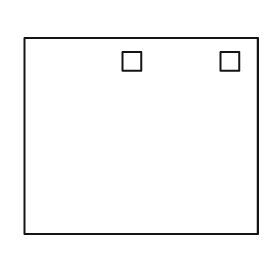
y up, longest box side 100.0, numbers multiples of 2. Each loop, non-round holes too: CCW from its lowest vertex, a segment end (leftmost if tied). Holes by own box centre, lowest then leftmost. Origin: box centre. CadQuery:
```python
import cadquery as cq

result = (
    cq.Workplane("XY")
    .moveTo(-50.0, -42.0)
    .lineTo(50.0, -42.0)
    .lineTo(50.0, 42.0)
    .lineTo(-50.0, 42.0)
    .close()
    .moveTo(-8.0, 28.0)
    .lineTo(0.0, 28.0)
    .lineTo(0.0, 36.0)
    .lineTo(-8.0, 36.0)
    .close()
    .moveTo(34.0, 28.0)
    .lineTo(42.0, 28.0)
    .lineTo(42.0, 36.0)
    .lineTo(34.0, 36.0)
    .close()
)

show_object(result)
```